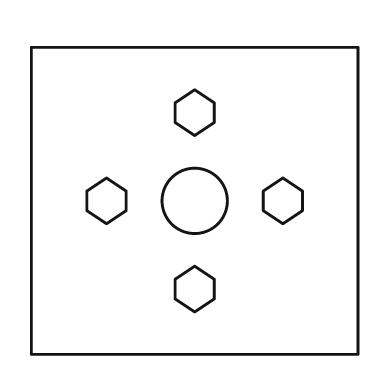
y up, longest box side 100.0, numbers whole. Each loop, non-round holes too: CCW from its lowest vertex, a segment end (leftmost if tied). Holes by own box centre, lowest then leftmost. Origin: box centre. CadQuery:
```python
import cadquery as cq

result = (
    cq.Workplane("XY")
    .moveTo(-50.0, -47.0)
    .lineTo(50.0, -47.0)
    .lineTo(50.0, 47.0)
    .lineTo(-50.0, 47.0)
    .close()
    .moveTo(0.0, -34.0)
    .lineTo(6.0, -30.0)
    .lineTo(6.0, -24.0)
    .lineTo(0.0, -20.0)
    .lineTo(-6.0, -24.0)
    .lineTo(-6.0, -30.0)
    .close()
    .moveTo(-27.0, -7.0)
    .lineTo(-21.0, -3.0)
    .lineTo(-21.0, 3.0)
    .lineTo(-27.0, 7.0)
    .lineTo(-33.0, 3.0)
    .lineTo(-33.0, -3.0)
    .close()
    .moveTo(0.0, 0.0)
    .circle(10.0)
    .moveTo(27.0, -7.0)
    .lineTo(33.0, -3.0)
    .lineTo(33.0, 3.0)
    .lineTo(27.0, 7.0)
    .lineTo(21.0, 3.0)
    .lineTo(21.0, -3.0)
    .close()
    .moveTo(0.0, 20.0)
    .lineTo(6.0, 24.0)
    .lineTo(6.0, 30.0)
    .lineTo(0.0, 34.0)
    .lineTo(-6.0, 30.0)
    .lineTo(-6.0, 24.0)
    .close()
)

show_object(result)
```